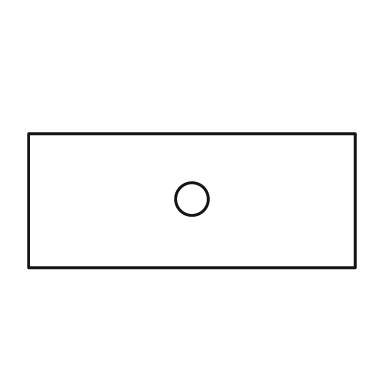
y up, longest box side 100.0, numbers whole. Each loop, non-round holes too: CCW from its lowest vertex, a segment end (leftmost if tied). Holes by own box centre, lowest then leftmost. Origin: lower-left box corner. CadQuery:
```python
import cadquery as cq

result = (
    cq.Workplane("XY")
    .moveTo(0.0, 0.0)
    .lineTo(100.0, 0.0)
    .lineTo(100.0, 41.0)
    .lineTo(0.0, 41.0)
    .close()
    .moveTo(50.0, 21.0)
    .circle(5.0)
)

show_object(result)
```